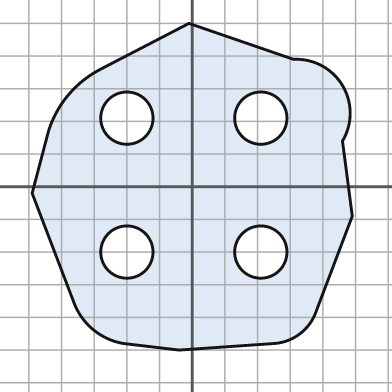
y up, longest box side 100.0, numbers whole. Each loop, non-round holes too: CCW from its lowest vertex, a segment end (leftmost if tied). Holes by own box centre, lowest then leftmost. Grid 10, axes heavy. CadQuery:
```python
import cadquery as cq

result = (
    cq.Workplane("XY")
    .moveTo(-4.0, -50.0)
    .lineTo(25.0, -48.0)
    .threePointArc((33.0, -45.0), (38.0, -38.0))
    .lineTo(49.0, -9.0)
    .lineTo(46.0, 14.0)
    .threePointArc((46.0, 31.0), (31.0, 39.0))
    .lineTo(-1.0, 50.0)
    .lineTo(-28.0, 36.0)
    .threePointArc((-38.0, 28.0), (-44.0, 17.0))
    .lineTo(-49.0, -2.0)
    .lineTo(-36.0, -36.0)
    .threePointArc((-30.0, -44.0), (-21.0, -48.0))
    .close()
    .moveTo(-20.0, -20.0)
    .circle(8.0)
    .moveTo(21.0, -20.0)
    .circle(8.0)
    .moveTo(-20.0, 21.0)
    .circle(8.0)
    .moveTo(21.0, 21.0)
    .circle(8.0)
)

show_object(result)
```